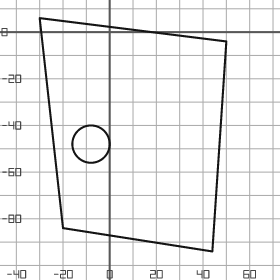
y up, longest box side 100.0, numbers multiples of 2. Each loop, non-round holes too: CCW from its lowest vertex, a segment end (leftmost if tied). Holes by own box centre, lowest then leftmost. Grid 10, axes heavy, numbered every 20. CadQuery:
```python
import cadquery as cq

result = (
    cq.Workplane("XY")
    .moveTo(44.0, -94.0)
    .lineTo(50.0, -4.0)
    .lineTo(-30.0, 6.0)
    .lineTo(-20.0, -84.0)
    .close()
    .moveTo(-8.0, -48.0)
    .circle(8.0)
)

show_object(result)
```